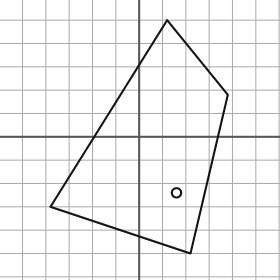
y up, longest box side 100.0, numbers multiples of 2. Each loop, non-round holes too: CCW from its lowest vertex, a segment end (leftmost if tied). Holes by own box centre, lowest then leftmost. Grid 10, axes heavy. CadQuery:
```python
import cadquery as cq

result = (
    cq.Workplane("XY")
    .moveTo(22.0, -50.0)
    .lineTo(38.0, 18.0)
    .lineTo(12.0, 50.0)
    .lineTo(-38.0, -30.0)
    .close()
    .moveTo(16.0, -24.0)
    .circle(2.0)
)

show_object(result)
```